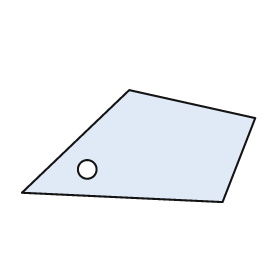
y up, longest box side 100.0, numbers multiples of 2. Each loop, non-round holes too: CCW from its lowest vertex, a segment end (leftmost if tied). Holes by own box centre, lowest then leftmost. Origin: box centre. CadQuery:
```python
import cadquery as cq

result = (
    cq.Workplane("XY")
    .moveTo(36.0, -24.0)
    .lineTo(50.0, 12.0)
    .lineTo(-4.0, 24.0)
    .lineTo(-50.0, -20.0)
    .close()
    .moveTo(-22.0, -10.0)
    .circle(4.0)
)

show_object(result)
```